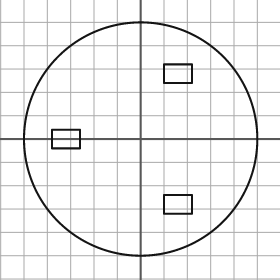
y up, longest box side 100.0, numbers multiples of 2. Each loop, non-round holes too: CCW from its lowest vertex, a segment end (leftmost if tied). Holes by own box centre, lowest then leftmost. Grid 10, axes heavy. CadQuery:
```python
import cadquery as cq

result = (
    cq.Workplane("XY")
    .moveTo(0.0, 0.0)
    .circle(50.0)
    .moveTo(10.0, -32.0)
    .lineTo(22.0, -32.0)
    .lineTo(22.0, -24.0)
    .lineTo(10.0, -24.0)
    .close()
    .moveTo(-38.0, -4.0)
    .lineTo(-26.0, -4.0)
    .lineTo(-26.0, 4.0)
    .lineTo(-38.0, 4.0)
    .close()
    .moveTo(10.0, 24.0)
    .lineTo(22.0, 24.0)
    .lineTo(22.0, 32.0)
    .lineTo(10.0, 32.0)
    .close()
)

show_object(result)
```